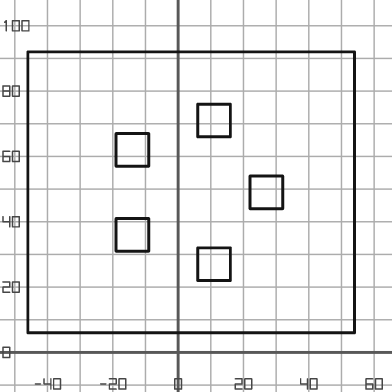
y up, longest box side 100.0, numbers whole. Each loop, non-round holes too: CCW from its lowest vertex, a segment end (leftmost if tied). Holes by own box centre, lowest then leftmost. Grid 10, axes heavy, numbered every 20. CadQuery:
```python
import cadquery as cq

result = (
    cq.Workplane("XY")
    .moveTo(-46.0, 6.0)
    .lineTo(54.0, 6.0)
    .lineTo(54.0, 92.0)
    .lineTo(-46.0, 92.0)
    .close()
    .moveTo(6.0, 22.0)
    .lineTo(16.0, 22.0)
    .lineTo(16.0, 32.0)
    .lineTo(6.0, 32.0)
    .close()
    .moveTo(-19.0, 31.0)
    .lineTo(-9.0, 31.0)
    .lineTo(-9.0, 41.0)
    .lineTo(-19.0, 41.0)
    .close()
    .moveTo(22.0, 44.0)
    .lineTo(32.0, 44.0)
    .lineTo(32.0, 54.0)
    .lineTo(22.0, 54.0)
    .close()
    .moveTo(-19.0, 57.0)
    .lineTo(-9.0, 57.0)
    .lineTo(-9.0, 67.0)
    .lineTo(-19.0, 67.0)
    .close()
    .moveTo(6.0, 66.0)
    .lineTo(16.0, 66.0)
    .lineTo(16.0, 76.0)
    .lineTo(6.0, 76.0)
    .close()
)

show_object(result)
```